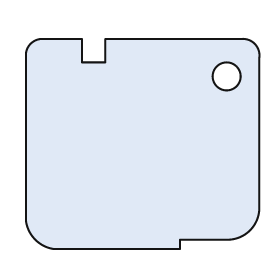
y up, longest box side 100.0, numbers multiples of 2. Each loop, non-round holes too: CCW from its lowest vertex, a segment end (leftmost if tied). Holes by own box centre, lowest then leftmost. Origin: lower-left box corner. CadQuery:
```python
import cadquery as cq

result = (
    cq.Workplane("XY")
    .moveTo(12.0, 0.0)
    .lineTo(66.0, 0.0)
    .lineTo(66.0, 4.0)
    .lineTo(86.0, 4.0)
    .threePointArc((96.0, 8.0), (100.0, 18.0))
    .lineTo(100.0, 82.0)
    .threePointArc((98.0, 88.0), (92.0, 90.0))
    .lineTo(34.0, 90.0)
    .lineTo(34.0, 80.0)
    .lineTo(24.0, 80.0)
    .lineTo(24.0, 90.0)
    .lineTo(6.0, 90.0)
    .threePointArc((2.0, 88.0), (0.0, 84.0))
    .lineTo(0.0, 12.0)
    .threePointArc((4.0, 4.0), (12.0, 0.0))
    .close()
    .moveTo(86.0, 74.0)
    .circle(6.0)
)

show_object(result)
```